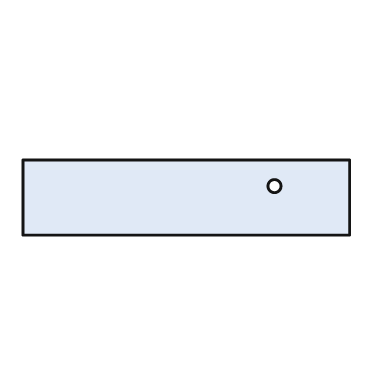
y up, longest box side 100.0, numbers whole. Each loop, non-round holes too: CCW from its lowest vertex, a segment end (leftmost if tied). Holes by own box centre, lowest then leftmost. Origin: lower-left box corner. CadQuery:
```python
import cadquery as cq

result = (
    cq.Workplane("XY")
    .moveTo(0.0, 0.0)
    .lineTo(100.0, 0.0)
    .lineTo(100.0, 23.0)
    .lineTo(0.0, 23.0)
    .close()
    .moveTo(77.0, 15.0)
    .circle(2.0)
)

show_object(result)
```